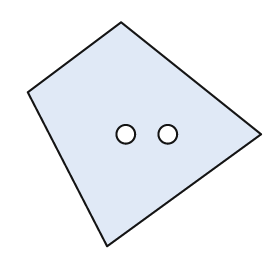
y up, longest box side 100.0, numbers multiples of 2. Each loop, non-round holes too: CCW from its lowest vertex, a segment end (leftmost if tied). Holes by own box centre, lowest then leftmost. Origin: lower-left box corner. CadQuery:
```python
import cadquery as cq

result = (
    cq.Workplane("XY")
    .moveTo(34.0, 0.0)
    .lineTo(100.0, 48.0)
    .lineTo(40.0, 96.0)
    .lineTo(0.0, 66.0)
    .close()
    .moveTo(42.0, 48.0)
    .circle(4.0)
    .moveTo(60.0, 48.0)
    .circle(4.0)
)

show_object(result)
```